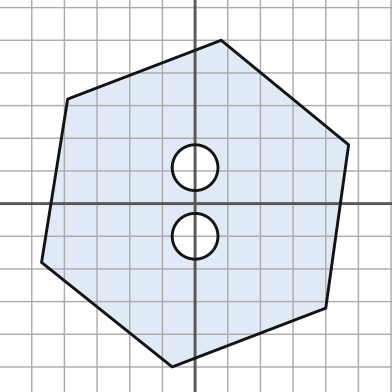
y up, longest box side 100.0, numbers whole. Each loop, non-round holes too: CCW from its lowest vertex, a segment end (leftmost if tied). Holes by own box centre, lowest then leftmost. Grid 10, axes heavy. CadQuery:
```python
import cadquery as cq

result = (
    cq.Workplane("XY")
    .moveTo(-7.0, -50.0)
    .lineTo(40.0, -32.0)
    .lineTo(47.0, 18.0)
    .lineTo(8.0, 50.0)
    .lineTo(-39.0, 32.0)
    .lineTo(-47.0, -18.0)
    .close()
    .moveTo(0.0, -10.0)
    .circle(7.0)
    .moveTo(0.0, 11.0)
    .circle(7.0)
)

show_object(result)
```